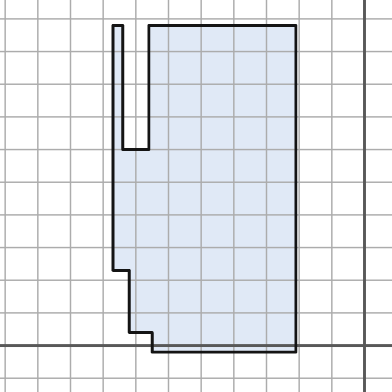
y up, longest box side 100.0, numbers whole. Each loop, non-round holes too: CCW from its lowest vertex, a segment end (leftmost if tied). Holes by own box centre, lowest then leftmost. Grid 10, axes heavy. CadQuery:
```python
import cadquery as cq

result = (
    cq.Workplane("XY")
    .moveTo(-65.0, -2.0)
    .lineTo(-21.0, -2.0)
    .lineTo(-21.0, 98.0)
    .lineTo(-66.0, 98.0)
    .lineTo(-66.0, 60.0)
    .lineTo(-74.0, 60.0)
    .lineTo(-74.0, 98.0)
    .lineTo(-77.0, 98.0)
    .lineTo(-77.0, 23.0)
    .lineTo(-72.0, 23.0)
    .lineTo(-72.0, 4.0)
    .lineTo(-65.0, 4.0)
    .close()
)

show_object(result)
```